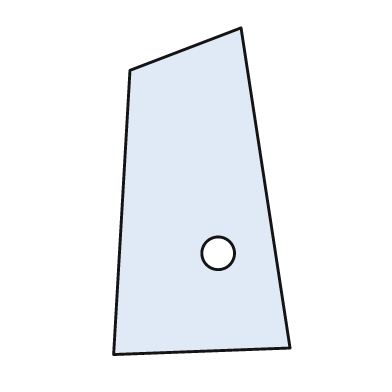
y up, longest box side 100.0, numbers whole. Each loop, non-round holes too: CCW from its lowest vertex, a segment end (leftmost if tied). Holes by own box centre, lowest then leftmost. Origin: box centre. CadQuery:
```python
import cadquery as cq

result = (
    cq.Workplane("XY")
    .moveTo(-27.0, -50.0)
    .lineTo(27.0, -48.0)
    .lineTo(12.0, 50.0)
    .lineTo(-22.0, 37.0)
    .close()
    .moveTo(5.0, -19.0)
    .circle(5.0)
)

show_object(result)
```